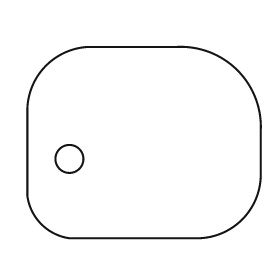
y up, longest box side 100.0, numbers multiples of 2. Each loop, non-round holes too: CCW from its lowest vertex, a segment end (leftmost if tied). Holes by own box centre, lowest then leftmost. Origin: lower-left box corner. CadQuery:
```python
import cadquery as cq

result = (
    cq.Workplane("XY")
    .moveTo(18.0, 0.0)
    .lineTo(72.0, 0.0)
    .threePointArc((92.0, 8.0), (100.0, 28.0))
    .lineTo(100.0, 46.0)
    .threePointArc((90.0, 72.0), (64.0, 82.0))
    .lineTo(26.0, 82.0)
    .threePointArc((8.0, 74.0), (0.0, 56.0))
    .lineTo(0.0, 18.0)
    .threePointArc((6.0, 6.0), (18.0, 0.0))
    .close()
    .moveTo(18.0, 34.0)
    .circle(6.0)
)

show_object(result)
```